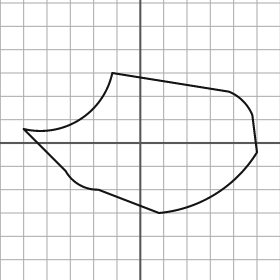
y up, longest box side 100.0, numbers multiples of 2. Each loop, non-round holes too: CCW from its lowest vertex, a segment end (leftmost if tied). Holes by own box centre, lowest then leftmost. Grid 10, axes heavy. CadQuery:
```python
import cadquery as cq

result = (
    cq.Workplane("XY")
    .moveTo(8.0, -30.0)
    .threePointArc((32.0, -22.0), (50.0, -4.0))
    .lineTo(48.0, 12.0)
    .threePointArc((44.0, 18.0), (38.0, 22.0))
    .lineTo(-12.0, 30.0)
    .threePointArc((-26.0, 10.0), (-50.0, 6.0))
    .lineTo(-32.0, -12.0)
    .threePointArc((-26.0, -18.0), (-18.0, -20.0))
    .close()
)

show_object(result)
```